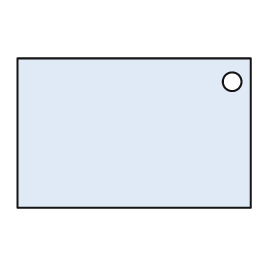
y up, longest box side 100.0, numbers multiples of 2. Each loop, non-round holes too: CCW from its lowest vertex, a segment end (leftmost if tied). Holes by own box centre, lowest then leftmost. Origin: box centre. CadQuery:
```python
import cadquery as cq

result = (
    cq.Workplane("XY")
    .moveTo(-50.0, -32.0)
    .lineTo(50.0, -32.0)
    .lineTo(50.0, 32.0)
    .lineTo(-50.0, 32.0)
    .close()
    .moveTo(42.0, 22.0)
    .circle(4.0)
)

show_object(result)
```